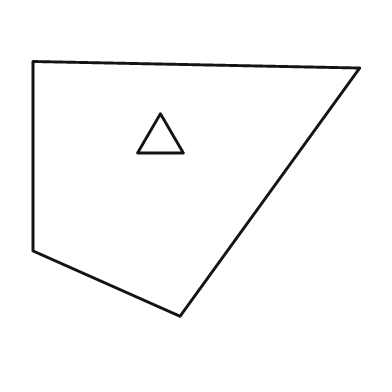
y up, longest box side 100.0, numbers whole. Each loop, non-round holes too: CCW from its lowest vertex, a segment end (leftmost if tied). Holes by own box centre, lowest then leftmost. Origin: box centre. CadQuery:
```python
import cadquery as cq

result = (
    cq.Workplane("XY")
    .moveTo(-5.0, -39.0)
    .lineTo(50.0, 37.0)
    .lineTo(-50.0, 39.0)
    .lineTo(-50.0, -19.0)
    .close()
    .moveTo(-18.0, 11.0)
    .lineTo(-4.0, 11.0)
    .lineTo(-11.0, 23.0)
    .close()
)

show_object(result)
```